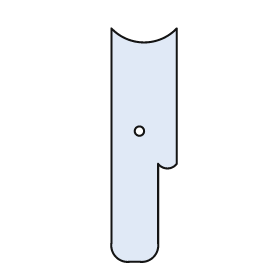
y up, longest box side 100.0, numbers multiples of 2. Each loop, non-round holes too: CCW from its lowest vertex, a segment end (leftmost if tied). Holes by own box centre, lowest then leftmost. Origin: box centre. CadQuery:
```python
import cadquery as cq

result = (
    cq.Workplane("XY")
    .moveTo(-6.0, -50.0)
    .lineTo(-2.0, -50.0)
    .threePointArc((4.0, -48.0), (6.0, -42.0))
    .lineTo(6.0, -8.0)
    .threePointArc((10.0, -10.0), (14.0, -8.0))
    .lineTo(14.0, 50.0)
    .threePointArc((0.0, 44.0), (-14.0, 50.0))
    .lineTo(-14.0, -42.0)
    .threePointArc((-12.0, -48.0), (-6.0, -50.0))
    .close()
    .moveTo(-2.0, 6.0)
    .circle(2.0)
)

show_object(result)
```